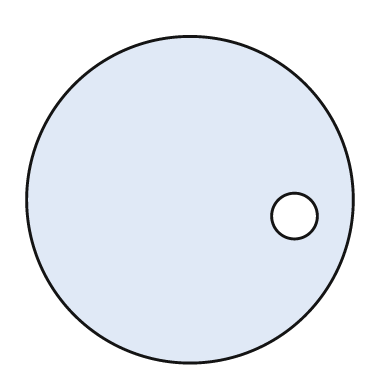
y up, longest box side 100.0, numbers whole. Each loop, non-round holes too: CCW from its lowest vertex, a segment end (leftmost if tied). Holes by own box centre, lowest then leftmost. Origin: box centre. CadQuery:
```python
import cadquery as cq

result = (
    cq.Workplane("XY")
    .moveTo(0.0, 0.0)
    .circle(50.0)
    .moveTo(32.0, -5.0)
    .circle(7.0)
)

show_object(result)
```